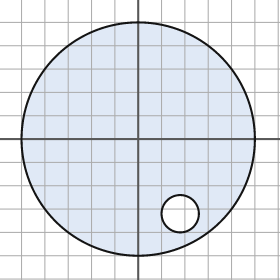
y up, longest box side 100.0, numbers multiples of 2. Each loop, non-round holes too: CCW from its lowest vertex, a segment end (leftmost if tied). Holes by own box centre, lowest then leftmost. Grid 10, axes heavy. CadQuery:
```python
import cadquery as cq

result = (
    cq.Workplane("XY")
    .moveTo(0.0, 0.0)
    .circle(50.0)
    .moveTo(18.0, -32.0)
    .circle(8.0)
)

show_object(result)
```